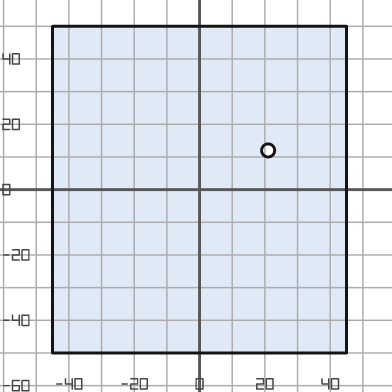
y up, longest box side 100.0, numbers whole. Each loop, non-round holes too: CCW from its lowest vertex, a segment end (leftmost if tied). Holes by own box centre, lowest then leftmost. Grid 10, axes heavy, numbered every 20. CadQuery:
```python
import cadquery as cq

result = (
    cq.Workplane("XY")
    .moveTo(-45.0, -50.0)
    .lineTo(45.0, -50.0)
    .lineTo(45.0, 50.0)
    .lineTo(-45.0, 50.0)
    .close()
    .moveTo(21.0, 12.0)
    .circle(2.0)
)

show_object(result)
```